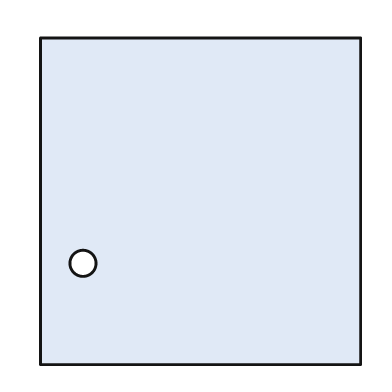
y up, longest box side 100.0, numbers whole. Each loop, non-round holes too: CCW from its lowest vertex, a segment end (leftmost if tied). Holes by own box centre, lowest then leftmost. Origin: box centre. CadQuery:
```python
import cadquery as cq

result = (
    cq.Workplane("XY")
    .moveTo(-49.0, -50.0)
    .lineTo(49.0, -50.0)
    .lineTo(49.0, 50.0)
    .lineTo(-49.0, 50.0)
    .close()
    .moveTo(-36.0, -19.0)
    .circle(4.0)
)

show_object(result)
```